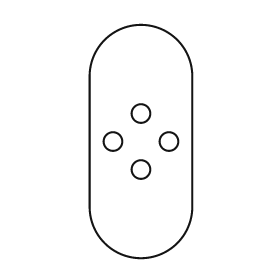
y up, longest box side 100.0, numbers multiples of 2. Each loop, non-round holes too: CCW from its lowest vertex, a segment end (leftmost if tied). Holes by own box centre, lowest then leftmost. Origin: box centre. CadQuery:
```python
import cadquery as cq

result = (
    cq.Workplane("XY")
    .moveTo(-22.0, -28.0)
    .threePointArc((0.0, -50.0), (22.0, -28.0))
    .lineTo(22.0, 28.0)
    .threePointArc((0.0, 50.0), (-22.0, 28.0))
    .close()
    .moveTo(0.0, -12.0)
    .circle(4.0)
    .moveTo(-12.0, 0.0)
    .circle(4.0)
    .moveTo(12.0, 0.0)
    .circle(4.0)
    .moveTo(0.0, 12.0)
    .circle(4.0)
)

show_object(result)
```